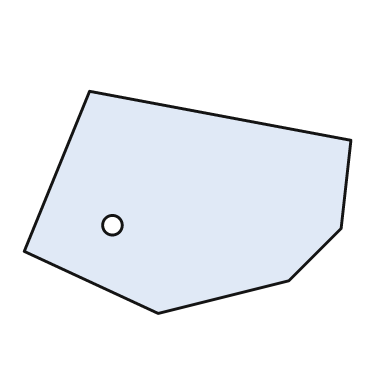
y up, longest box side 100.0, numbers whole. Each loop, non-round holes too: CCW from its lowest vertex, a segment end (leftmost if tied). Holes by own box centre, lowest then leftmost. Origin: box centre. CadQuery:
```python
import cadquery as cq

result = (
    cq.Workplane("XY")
    .moveTo(-9.0, -34.0)
    .lineTo(31.0, -24.0)
    .lineTo(47.0, -8.0)
    .lineTo(50.0, 19.0)
    .lineTo(-30.0, 34.0)
    .lineTo(-50.0, -15.0)
    .close()
    .moveTo(-23.0, -7.0)
    .circle(3.0)
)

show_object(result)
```